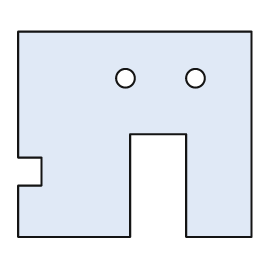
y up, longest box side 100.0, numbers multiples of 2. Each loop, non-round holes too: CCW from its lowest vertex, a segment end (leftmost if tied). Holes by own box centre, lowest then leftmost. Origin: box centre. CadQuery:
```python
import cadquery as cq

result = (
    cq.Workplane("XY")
    .moveTo(-50.0, -44.0)
    .lineTo(-2.0, -44.0)
    .lineTo(-2.0, 0.0)
    .lineTo(22.0, 0.0)
    .lineTo(22.0, -44.0)
    .lineTo(50.0, -44.0)
    .lineTo(50.0, 44.0)
    .lineTo(-50.0, 44.0)
    .lineTo(-50.0, -10.0)
    .lineTo(-40.0, -10.0)
    .lineTo(-40.0, -22.0)
    .lineTo(-50.0, -22.0)
    .close()
    .moveTo(-4.0, 24.0)
    .circle(4.0)
    .moveTo(26.0, 24.0)
    .circle(4.0)
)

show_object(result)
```